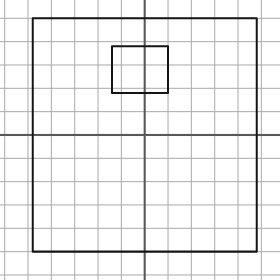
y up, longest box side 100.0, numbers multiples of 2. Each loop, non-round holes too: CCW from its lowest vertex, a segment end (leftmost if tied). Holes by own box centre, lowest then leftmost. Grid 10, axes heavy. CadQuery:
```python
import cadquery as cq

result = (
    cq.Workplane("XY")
    .moveTo(-48.0, -50.0)
    .lineTo(48.0, -50.0)
    .lineTo(48.0, 50.0)
    .lineTo(-48.0, 50.0)
    .close()
    .moveTo(-14.0, 18.0)
    .lineTo(10.0, 18.0)
    .lineTo(10.0, 38.0)
    .lineTo(-14.0, 38.0)
    .close()
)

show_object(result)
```